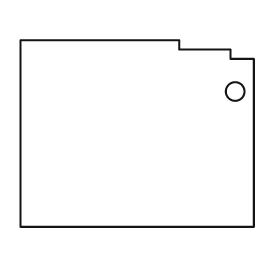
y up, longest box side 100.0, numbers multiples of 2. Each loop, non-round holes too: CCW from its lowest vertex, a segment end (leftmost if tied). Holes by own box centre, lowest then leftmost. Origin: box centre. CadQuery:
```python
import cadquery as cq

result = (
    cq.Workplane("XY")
    .moveTo(-50.0, -40.0)
    .lineTo(50.0, -40.0)
    .lineTo(50.0, 32.0)
    .lineTo(40.0, 32.0)
    .lineTo(40.0, 36.0)
    .lineTo(18.0, 36.0)
    .lineTo(18.0, 40.0)
    .lineTo(-50.0, 40.0)
    .close()
    .moveTo(42.0, 18.0)
    .circle(4.0)
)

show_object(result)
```